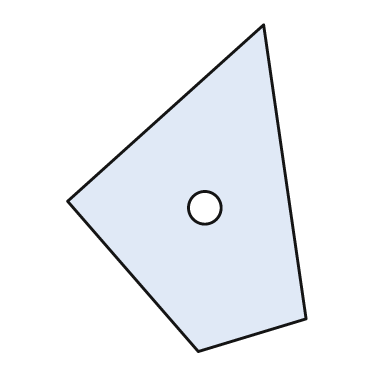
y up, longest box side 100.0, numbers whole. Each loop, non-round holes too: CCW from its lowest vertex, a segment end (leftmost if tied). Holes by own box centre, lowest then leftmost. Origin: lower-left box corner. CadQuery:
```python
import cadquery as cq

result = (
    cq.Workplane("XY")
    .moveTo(40.0, 0.0)
    .lineTo(73.0, 10.0)
    .lineTo(60.0, 100.0)
    .lineTo(0.0, 46.0)
    .close()
    .moveTo(42.0, 44.0)
    .circle(5.0)
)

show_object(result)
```